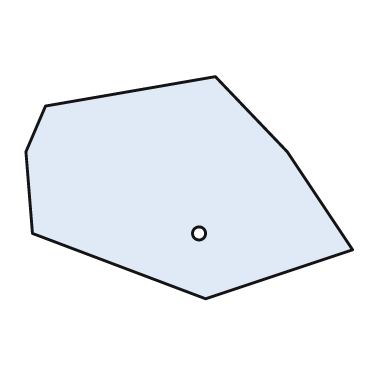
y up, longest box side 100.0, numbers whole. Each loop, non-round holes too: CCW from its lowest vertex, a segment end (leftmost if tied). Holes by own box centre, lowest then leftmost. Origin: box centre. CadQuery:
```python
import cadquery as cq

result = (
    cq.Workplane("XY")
    .moveTo(5.0, -34.0)
    .lineTo(50.0, -19.0)
    .lineTo(30.0, 11.0)
    .lineTo(8.0, 34.0)
    .lineTo(-44.0, 25.0)
    .lineTo(-50.0, 11.0)
    .lineTo(-48.0, -14.0)
    .close()
    .moveTo(3.0, -14.0)
    .circle(2.0)
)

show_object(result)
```